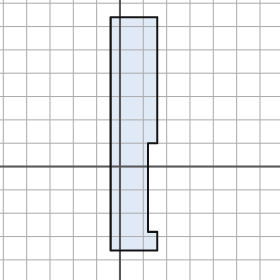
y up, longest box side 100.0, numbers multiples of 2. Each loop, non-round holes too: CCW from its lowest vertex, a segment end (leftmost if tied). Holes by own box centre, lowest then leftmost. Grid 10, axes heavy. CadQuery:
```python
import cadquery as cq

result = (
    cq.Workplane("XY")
    .moveTo(-4.0, -36.0)
    .lineTo(16.0, -36.0)
    .lineTo(16.0, -28.0)
    .lineTo(12.0, -28.0)
    .lineTo(12.0, 10.0)
    .lineTo(16.0, 10.0)
    .lineTo(16.0, 64.0)
    .lineTo(-4.0, 64.0)
    .close()
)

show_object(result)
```